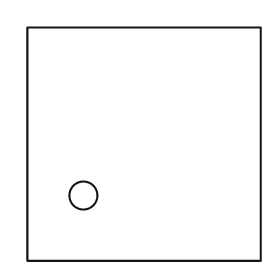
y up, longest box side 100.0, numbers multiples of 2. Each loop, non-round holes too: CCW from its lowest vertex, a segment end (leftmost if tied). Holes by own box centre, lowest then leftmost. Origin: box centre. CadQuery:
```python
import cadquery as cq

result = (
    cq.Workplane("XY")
    .moveTo(-50.0, -50.0)
    .lineTo(50.0, -50.0)
    .lineTo(50.0, 50.0)
    .lineTo(-50.0, 50.0)
    .close()
    .moveTo(-26.0, -22.0)
    .circle(6.0)
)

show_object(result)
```